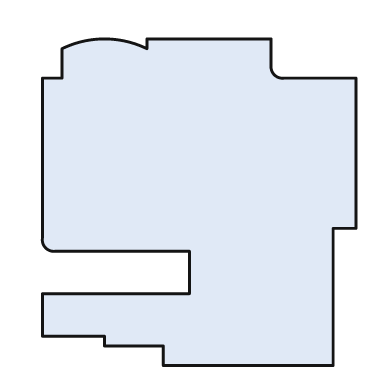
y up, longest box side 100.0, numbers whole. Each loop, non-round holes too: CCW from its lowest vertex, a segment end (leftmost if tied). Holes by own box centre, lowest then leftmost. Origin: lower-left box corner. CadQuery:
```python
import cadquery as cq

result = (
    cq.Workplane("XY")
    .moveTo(37.0, 0.0)
    .lineTo(89.0, 0.0)
    .lineTo(89.0, 42.0)
    .lineTo(96.0, 42.0)
    .lineTo(96.0, 88.0)
    .lineTo(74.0, 88.0)
    .threePointArc((71.0, 89.0), (70.0, 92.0))
    .lineTo(70.0, 100.0)
    .lineTo(32.0, 100.0)
    .lineTo(32.0, 97.0)
    .threePointArc((19.0, 100.0), (6.0, 97.0))
    .lineTo(6.0, 88.0)
    .lineTo(0.0, 88.0)
    .lineTo(0.0, 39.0)
    .threePointArc((1.0, 36.0), (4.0, 35.0))
    .lineTo(45.0, 35.0)
    .lineTo(45.0, 22.0)
    .lineTo(0.0, 22.0)
    .lineTo(0.0, 9.0)
    .lineTo(19.0, 9.0)
    .lineTo(19.0, 6.0)
    .lineTo(37.0, 6.0)
    .close()
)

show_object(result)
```